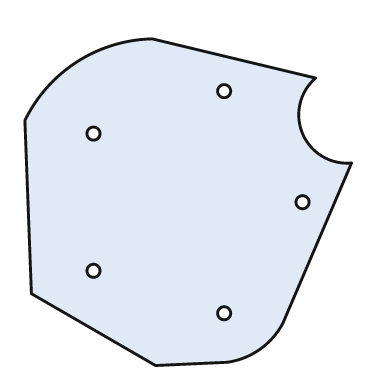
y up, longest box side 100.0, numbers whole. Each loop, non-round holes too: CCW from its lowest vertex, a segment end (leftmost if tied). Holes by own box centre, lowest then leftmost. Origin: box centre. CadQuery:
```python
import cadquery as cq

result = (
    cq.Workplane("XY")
    .moveTo(-10.0, -50.0)
    .lineTo(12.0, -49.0)
    .threePointArc((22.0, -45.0), (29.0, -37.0))
    .lineTo(50.0, 12.0)
    .threePointArc((35.0, 21.0), (39.0, 38.0))
    .lineTo(-11.0, 50.0)
    .threePointArc((-34.0, 43.0), (-50.0, 25.0))
    .lineTo(-48.0, -28.0)
    .close()
    .moveTo(11.0, -34.0)
    .circle(2.0)
    .moveTo(-29.0, -21.0)
    .circle(2.0)
    .moveTo(35.0, 0.0)
    .circle(2.0)
    .moveTo(-29.0, 21.0)
    .circle(2.0)
    .moveTo(11.0, 34.0)
    .circle(2.0)
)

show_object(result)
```